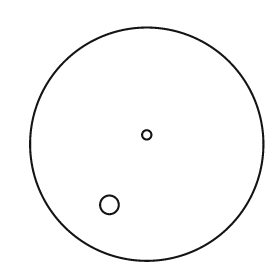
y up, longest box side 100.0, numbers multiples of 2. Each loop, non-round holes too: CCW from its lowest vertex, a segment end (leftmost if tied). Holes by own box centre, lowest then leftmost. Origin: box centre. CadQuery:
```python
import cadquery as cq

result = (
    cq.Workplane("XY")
    .moveTo(0.0, 0.0)
    .circle(50.0)
    .moveTo(-16.0, -26.0)
    .circle(4.0)
    .moveTo(0.0, 4.0)
    .circle(2.0)
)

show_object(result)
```